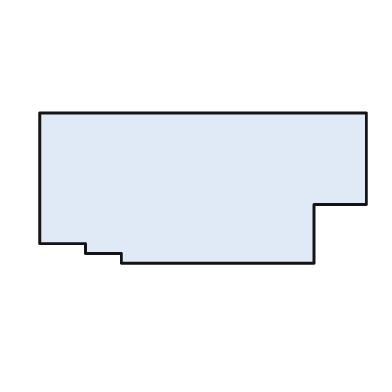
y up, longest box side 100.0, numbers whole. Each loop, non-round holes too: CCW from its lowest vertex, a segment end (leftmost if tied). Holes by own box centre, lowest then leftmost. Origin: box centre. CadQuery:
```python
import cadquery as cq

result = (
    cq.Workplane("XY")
    .moveTo(-25.0, -23.0)
    .lineTo(34.0, -23.0)
    .lineTo(34.0, -5.0)
    .lineTo(50.0, -5.0)
    .lineTo(50.0, 23.0)
    .lineTo(-50.0, 23.0)
    .lineTo(-50.0, -17.0)
    .lineTo(-36.0, -17.0)
    .lineTo(-36.0, -20.0)
    .lineTo(-25.0, -20.0)
    .close()
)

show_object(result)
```